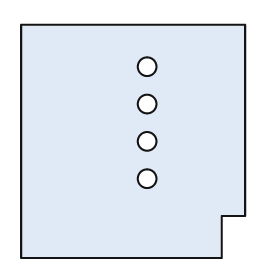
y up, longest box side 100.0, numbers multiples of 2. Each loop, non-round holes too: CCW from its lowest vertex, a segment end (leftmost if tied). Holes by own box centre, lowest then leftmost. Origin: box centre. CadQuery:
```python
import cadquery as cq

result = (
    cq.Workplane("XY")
    .moveTo(-48.0, -50.0)
    .lineTo(38.0, -50.0)
    .lineTo(38.0, -32.0)
    .lineTo(48.0, -32.0)
    .lineTo(48.0, 50.0)
    .lineTo(-48.0, 50.0)
    .close()
    .moveTo(6.0, -16.0)
    .circle(4.0)
    .moveTo(6.0, 0.0)
    .circle(4.0)
    .moveTo(6.0, 16.0)
    .circle(4.0)
    .moveTo(6.0, 32.0)
    .circle(4.0)
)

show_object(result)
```